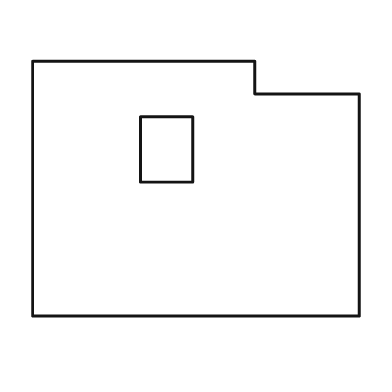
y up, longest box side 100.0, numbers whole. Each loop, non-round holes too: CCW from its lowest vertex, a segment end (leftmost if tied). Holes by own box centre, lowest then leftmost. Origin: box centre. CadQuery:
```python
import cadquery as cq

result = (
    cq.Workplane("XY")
    .moveTo(-50.0, -39.0)
    .lineTo(50.0, -39.0)
    .lineTo(50.0, 29.0)
    .lineTo(18.0, 29.0)
    .lineTo(18.0, 39.0)
    .lineTo(-50.0, 39.0)
    .close()
    .moveTo(-17.0, 2.0)
    .lineTo(-1.0, 2.0)
    .lineTo(-1.0, 22.0)
    .lineTo(-17.0, 22.0)
    .close()
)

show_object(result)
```